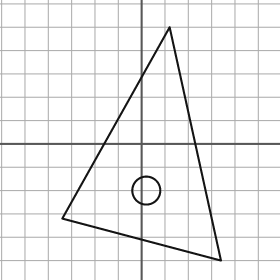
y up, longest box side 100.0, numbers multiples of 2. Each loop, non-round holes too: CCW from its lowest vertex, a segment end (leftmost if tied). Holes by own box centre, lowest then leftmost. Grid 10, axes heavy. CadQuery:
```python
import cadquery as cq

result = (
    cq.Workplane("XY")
    .moveTo(34.0, -50.0)
    .lineTo(12.0, 50.0)
    .lineTo(-34.0, -32.0)
    .close()
    .moveTo(2.0, -20.0)
    .circle(6.0)
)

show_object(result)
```